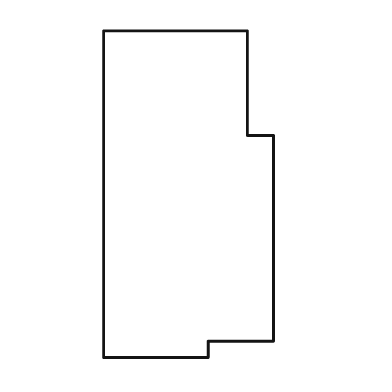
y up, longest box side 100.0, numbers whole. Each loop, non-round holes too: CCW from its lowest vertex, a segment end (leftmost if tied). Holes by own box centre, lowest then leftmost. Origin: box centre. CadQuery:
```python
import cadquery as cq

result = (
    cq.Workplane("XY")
    .moveTo(-26.0, -50.0)
    .lineTo(6.0, -50.0)
    .lineTo(6.0, -45.0)
    .lineTo(26.0, -45.0)
    .lineTo(26.0, 18.0)
    .lineTo(18.0, 18.0)
    .lineTo(18.0, 50.0)
    .lineTo(-26.0, 50.0)
    .close()
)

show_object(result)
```